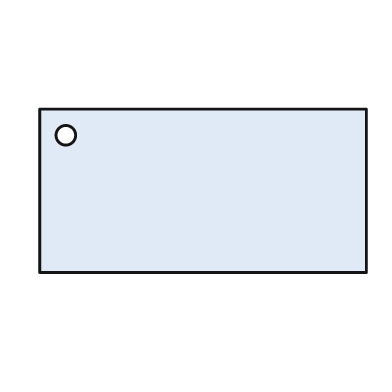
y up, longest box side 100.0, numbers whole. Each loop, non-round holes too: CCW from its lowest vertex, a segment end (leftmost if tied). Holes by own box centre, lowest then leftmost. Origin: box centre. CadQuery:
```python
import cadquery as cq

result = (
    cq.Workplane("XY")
    .moveTo(-50.0, -25.0)
    .lineTo(50.0, -25.0)
    .lineTo(50.0, 25.0)
    .lineTo(-50.0, 25.0)
    .close()
    .moveTo(-42.0, 17.0)
    .circle(3.0)
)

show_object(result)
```